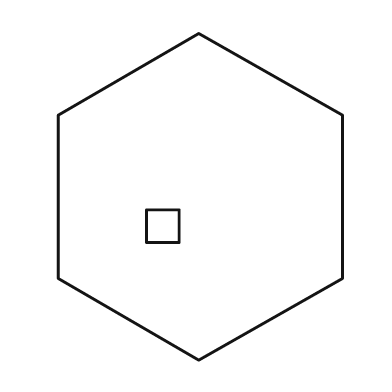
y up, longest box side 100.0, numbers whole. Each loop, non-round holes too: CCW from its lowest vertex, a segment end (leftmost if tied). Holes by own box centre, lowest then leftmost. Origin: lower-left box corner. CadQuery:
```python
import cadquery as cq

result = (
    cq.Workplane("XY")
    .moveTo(43.0, 0.0)
    .lineTo(87.0, 25.0)
    .lineTo(87.0, 75.0)
    .lineTo(43.0, 100.0)
    .lineTo(0.0, 75.0)
    .lineTo(0.0, 25.0)
    .close()
    .moveTo(27.0, 36.0)
    .lineTo(37.0, 36.0)
    .lineTo(37.0, 46.0)
    .lineTo(27.0, 46.0)
    .close()
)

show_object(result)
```